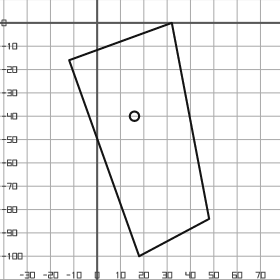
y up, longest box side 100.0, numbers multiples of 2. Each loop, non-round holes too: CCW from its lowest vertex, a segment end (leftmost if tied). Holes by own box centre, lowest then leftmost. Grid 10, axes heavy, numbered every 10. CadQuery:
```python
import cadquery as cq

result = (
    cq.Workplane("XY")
    .moveTo(18.0, -100.0)
    .lineTo(48.0, -84.0)
    .lineTo(32.0, 0.0)
    .lineTo(-12.0, -16.0)
    .close()
    .moveTo(16.0, -40.0)
    .circle(2.0)
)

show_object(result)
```